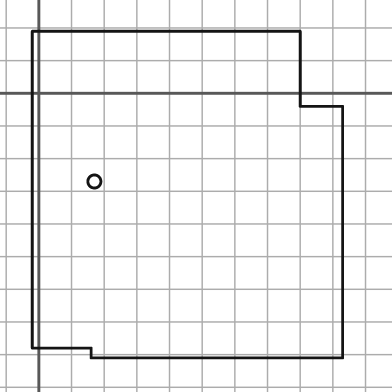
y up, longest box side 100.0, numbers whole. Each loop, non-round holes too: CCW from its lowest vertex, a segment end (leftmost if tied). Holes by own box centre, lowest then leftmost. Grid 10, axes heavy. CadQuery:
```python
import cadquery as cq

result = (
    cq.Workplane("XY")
    .moveTo(16.0, -81.0)
    .lineTo(93.0, -81.0)
    .lineTo(93.0, -4.0)
    .lineTo(80.0, -4.0)
    .lineTo(80.0, 19.0)
    .lineTo(-2.0, 19.0)
    .lineTo(-2.0, -78.0)
    .lineTo(16.0, -78.0)
    .close()
    .moveTo(17.0, -27.0)
    .circle(2.0)
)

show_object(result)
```